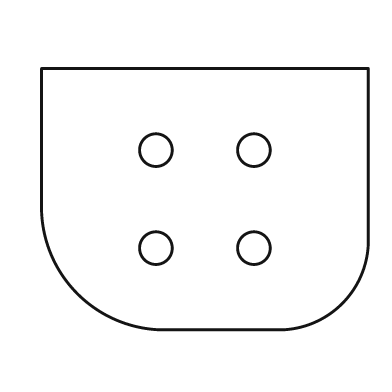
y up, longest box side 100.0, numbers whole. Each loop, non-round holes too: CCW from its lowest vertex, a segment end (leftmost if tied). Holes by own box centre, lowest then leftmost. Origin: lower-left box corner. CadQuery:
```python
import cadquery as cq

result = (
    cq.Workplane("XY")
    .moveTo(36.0, 0.0)
    .lineTo(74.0, 0.0)
    .threePointArc((92.0, 8.0), (100.0, 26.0))
    .lineTo(100.0, 80.0)
    .lineTo(0.0, 80.0)
    .lineTo(0.0, 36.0)
    .threePointArc((11.0, 11.0), (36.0, 0.0))
    .close()
    .moveTo(35.0, 25.0)
    .circle(5.0)
    .moveTo(65.0, 25.0)
    .circle(5.0)
    .moveTo(35.0, 55.0)
    .circle(5.0)
    .moveTo(65.0, 55.0)
    .circle(5.0)
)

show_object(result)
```